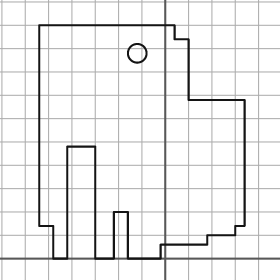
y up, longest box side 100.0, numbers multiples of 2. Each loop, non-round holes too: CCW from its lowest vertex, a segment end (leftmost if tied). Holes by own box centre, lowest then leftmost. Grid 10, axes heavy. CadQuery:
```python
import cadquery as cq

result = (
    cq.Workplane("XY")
    .moveTo(-48.0, 0.0)
    .lineTo(-42.0, 0.0)
    .lineTo(-42.0, 48.0)
    .lineTo(-30.0, 48.0)
    .lineTo(-30.0, 0.0)
    .lineTo(-22.0, 0.0)
    .lineTo(-22.0, 20.0)
    .lineTo(-16.0, 20.0)
    .lineTo(-16.0, 0.0)
    .lineTo(-2.0, 0.0)
    .lineTo(-2.0, 6.0)
    .lineTo(18.0, 6.0)
    .lineTo(18.0, 10.0)
    .lineTo(30.0, 10.0)
    .lineTo(30.0, 14.0)
    .lineTo(34.0, 14.0)
    .lineTo(34.0, 68.0)
    .lineTo(10.0, 68.0)
    .lineTo(10.0, 94.0)
    .lineTo(4.0, 94.0)
    .lineTo(4.0, 100.0)
    .lineTo(-54.0, 100.0)
    .lineTo(-54.0, 14.0)
    .lineTo(-48.0, 14.0)
    .close()
    .moveTo(-12.0, 88.0)
    .circle(4.0)
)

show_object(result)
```